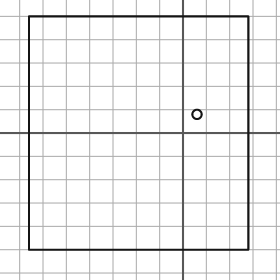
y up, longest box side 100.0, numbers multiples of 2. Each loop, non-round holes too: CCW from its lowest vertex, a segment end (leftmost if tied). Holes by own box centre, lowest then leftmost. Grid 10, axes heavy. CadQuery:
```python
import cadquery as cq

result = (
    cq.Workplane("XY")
    .moveTo(-66.0, -50.0)
    .lineTo(28.0, -50.0)
    .lineTo(28.0, 50.0)
    .lineTo(-66.0, 50.0)
    .close()
    .moveTo(6.0, 8.0)
    .circle(2.0)
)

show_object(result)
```